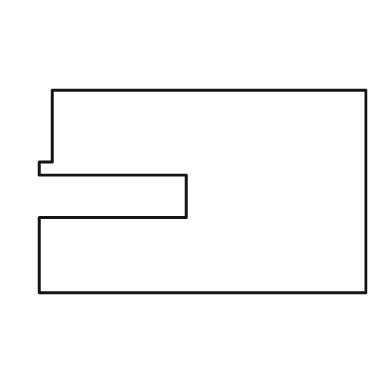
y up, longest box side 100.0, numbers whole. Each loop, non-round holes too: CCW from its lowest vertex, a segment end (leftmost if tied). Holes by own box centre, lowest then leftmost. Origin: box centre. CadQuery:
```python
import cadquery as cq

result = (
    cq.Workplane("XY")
    .moveTo(-50.0, -31.0)
    .lineTo(50.0, -31.0)
    .lineTo(50.0, 31.0)
    .lineTo(-46.0, 31.0)
    .lineTo(-46.0, 9.0)
    .lineTo(-50.0, 9.0)
    .lineTo(-50.0, 5.0)
    .lineTo(-5.0, 5.0)
    .lineTo(-5.0, -8.0)
    .lineTo(-50.0, -8.0)
    .close()
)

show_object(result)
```